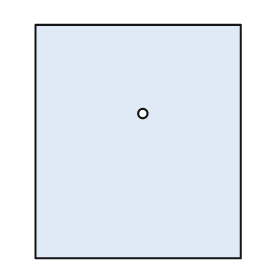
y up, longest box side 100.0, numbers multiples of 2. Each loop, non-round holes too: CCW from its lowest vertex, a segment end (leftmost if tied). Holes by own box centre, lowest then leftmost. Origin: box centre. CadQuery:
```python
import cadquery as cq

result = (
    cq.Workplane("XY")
    .moveTo(-44.0, -50.0)
    .lineTo(44.0, -50.0)
    .lineTo(44.0, 50.0)
    .lineTo(-44.0, 50.0)
    .close()
    .moveTo(2.0, 12.0)
    .circle(2.0)
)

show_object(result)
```